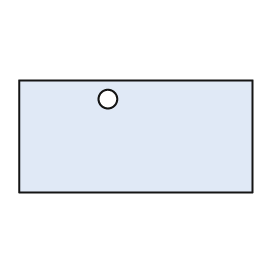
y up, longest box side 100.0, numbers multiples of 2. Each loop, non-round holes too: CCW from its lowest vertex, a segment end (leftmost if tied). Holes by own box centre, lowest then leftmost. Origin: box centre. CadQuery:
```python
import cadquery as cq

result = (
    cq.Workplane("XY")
    .moveTo(-50.0, -24.0)
    .lineTo(50.0, -24.0)
    .lineTo(50.0, 24.0)
    .lineTo(-50.0, 24.0)
    .close()
    .moveTo(-12.0, 16.0)
    .circle(4.0)
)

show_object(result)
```